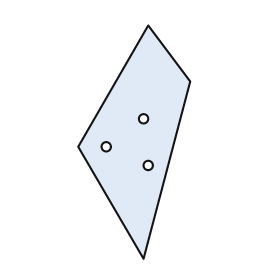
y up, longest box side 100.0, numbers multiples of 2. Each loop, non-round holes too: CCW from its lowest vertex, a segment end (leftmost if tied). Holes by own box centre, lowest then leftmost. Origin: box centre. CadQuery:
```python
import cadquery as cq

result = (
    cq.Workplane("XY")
    .moveTo(4.0, -50.0)
    .lineTo(24.0, 26.0)
    .lineTo(6.0, 50.0)
    .lineTo(-24.0, -2.0)
    .close()
    .moveTo(6.0, -10.0)
    .circle(2.0)
    .moveTo(-12.0, -2.0)
    .circle(2.0)
    .moveTo(4.0, 10.0)
    .circle(2.0)
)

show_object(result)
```